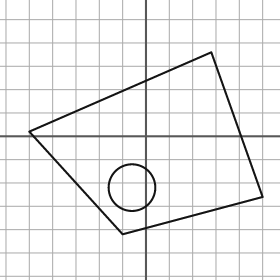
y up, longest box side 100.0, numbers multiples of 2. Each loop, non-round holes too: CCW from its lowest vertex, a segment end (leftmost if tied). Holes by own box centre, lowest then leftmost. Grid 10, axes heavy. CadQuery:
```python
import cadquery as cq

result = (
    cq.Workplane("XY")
    .moveTo(-10.0, -42.0)
    .lineTo(50.0, -26.0)
    .lineTo(28.0, 36.0)
    .lineTo(-50.0, 2.0)
    .close()
    .moveTo(-6.0, -22.0)
    .circle(10.0)
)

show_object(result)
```